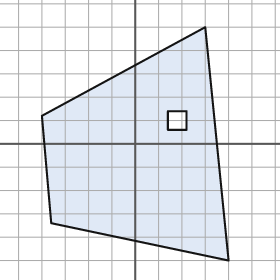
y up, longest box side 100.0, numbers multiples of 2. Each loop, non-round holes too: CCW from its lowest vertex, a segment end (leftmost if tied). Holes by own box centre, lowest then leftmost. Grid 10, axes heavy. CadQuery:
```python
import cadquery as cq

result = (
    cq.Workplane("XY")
    .moveTo(40.0, -50.0)
    .lineTo(30.0, 50.0)
    .lineTo(-40.0, 12.0)
    .lineTo(-36.0, -34.0)
    .close()
    .moveTo(14.0, 6.0)
    .lineTo(22.0, 6.0)
    .lineTo(22.0, 14.0)
    .lineTo(14.0, 14.0)
    .close()
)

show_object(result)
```